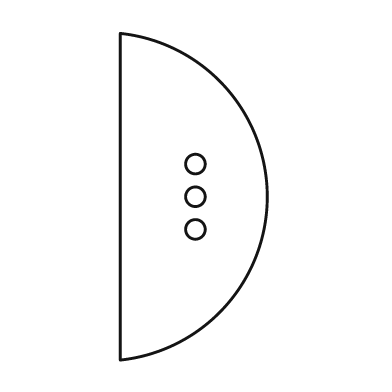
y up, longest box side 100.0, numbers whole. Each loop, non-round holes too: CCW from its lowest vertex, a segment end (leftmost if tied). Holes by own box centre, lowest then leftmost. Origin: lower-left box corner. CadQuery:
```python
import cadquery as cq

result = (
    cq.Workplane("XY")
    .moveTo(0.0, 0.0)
    .threePointArc((45.0, 50.0), (0.0, 100.0))
    .close()
    .moveTo(23.0, 40.0)
    .circle(3.0)
    .moveTo(23.0, 50.0)
    .circle(3.0)
    .moveTo(23.0, 60.0)
    .circle(3.0)
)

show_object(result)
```